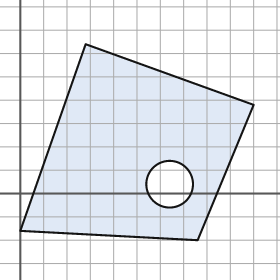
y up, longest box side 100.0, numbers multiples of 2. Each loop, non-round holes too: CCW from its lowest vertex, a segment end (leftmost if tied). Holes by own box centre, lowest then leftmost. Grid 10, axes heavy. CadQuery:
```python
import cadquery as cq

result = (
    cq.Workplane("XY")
    .moveTo(76.0, -20.0)
    .lineTo(100.0, 38.0)
    .lineTo(28.0, 64.0)
    .lineTo(0.0, -16.0)
    .close()
    .moveTo(64.0, 4.0)
    .circle(10.0)
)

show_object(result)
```